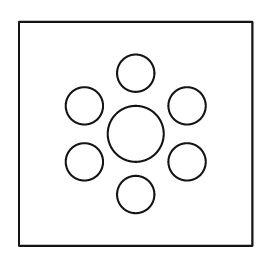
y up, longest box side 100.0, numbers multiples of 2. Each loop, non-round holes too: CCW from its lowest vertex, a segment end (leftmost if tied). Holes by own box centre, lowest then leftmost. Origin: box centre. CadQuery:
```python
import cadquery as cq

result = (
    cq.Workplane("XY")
    .moveTo(-50.0, -48.0)
    .lineTo(50.0, -48.0)
    .lineTo(50.0, 48.0)
    .lineTo(-50.0, 48.0)
    .close()
    .moveTo(0.0, -26.0)
    .circle(8.0)
    .moveTo(-22.0, -12.0)
    .circle(8.0)
    .moveTo(22.0, -12.0)
    .circle(8.0)
    .moveTo(0.0, 0.0)
    .circle(12.0)
    .moveTo(-22.0, 12.0)
    .circle(8.0)
    .moveTo(22.0, 12.0)
    .circle(8.0)
    .moveTo(0.0, 26.0)
    .circle(8.0)
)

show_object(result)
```